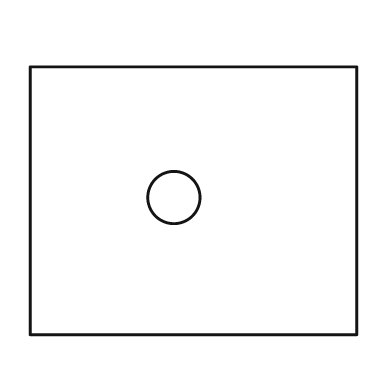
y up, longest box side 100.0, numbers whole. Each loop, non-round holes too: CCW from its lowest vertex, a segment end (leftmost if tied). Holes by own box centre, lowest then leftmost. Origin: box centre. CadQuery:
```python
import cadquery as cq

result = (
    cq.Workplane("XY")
    .moveTo(-50.0, -41.0)
    .lineTo(50.0, -41.0)
    .lineTo(50.0, 41.0)
    .lineTo(-50.0, 41.0)
    .close()
    .moveTo(-6.0, 1.0)
    .circle(8.0)
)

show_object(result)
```